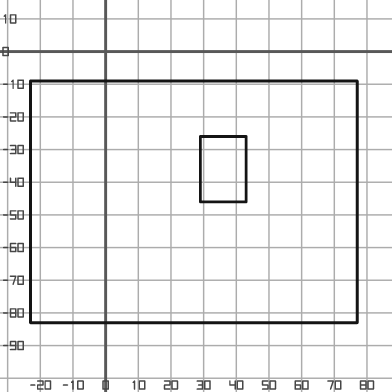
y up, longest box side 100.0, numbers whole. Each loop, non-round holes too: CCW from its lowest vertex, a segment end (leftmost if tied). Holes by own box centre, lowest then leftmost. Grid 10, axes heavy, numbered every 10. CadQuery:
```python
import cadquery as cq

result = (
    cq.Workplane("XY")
    .moveTo(-23.0, -83.0)
    .lineTo(77.0, -83.0)
    .lineTo(77.0, -9.0)
    .lineTo(-23.0, -9.0)
    .close()
    .moveTo(29.0, -46.0)
    .lineTo(43.0, -46.0)
    .lineTo(43.0, -26.0)
    .lineTo(29.0, -26.0)
    .close()
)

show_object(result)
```